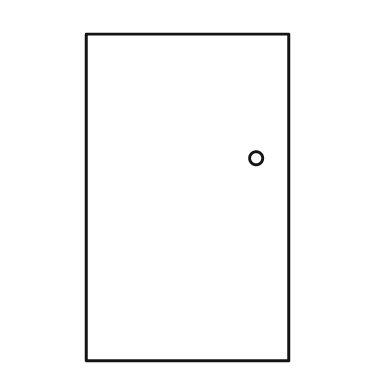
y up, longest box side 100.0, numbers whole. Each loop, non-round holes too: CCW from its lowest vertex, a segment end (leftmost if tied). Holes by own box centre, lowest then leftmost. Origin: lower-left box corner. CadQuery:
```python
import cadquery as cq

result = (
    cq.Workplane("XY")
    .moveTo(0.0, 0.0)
    .lineTo(62.0, 0.0)
    .lineTo(62.0, 100.0)
    .lineTo(0.0, 100.0)
    .close()
    .moveTo(52.0, 62.0)
    .circle(2.0)
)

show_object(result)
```